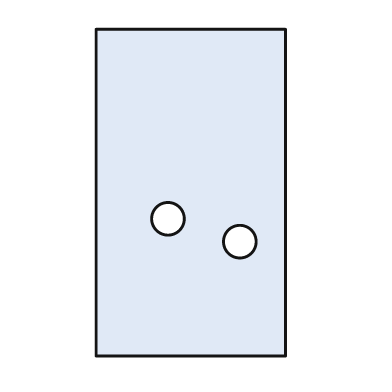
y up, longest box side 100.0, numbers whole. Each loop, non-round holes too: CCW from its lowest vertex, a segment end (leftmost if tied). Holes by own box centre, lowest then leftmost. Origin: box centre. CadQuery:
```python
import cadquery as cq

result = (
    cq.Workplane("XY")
    .moveTo(-29.0, -50.0)
    .lineTo(29.0, -50.0)
    .lineTo(29.0, 50.0)
    .lineTo(-29.0, 50.0)
    .close()
    .moveTo(15.0, -15.0)
    .circle(5.0)
    .moveTo(-7.0, -8.0)
    .circle(5.0)
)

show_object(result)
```